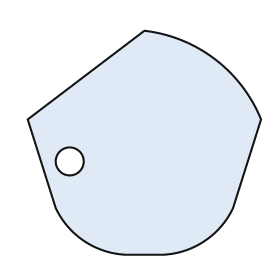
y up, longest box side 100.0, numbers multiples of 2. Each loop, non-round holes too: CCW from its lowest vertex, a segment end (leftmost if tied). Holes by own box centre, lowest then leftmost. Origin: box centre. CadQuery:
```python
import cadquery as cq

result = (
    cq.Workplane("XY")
    .moveTo(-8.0, -48.0)
    .lineTo(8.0, -48.0)
    .threePointArc((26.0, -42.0), (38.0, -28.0))
    .lineTo(50.0, 10.0)
    .threePointArc((30.0, 36.0), (0.0, 48.0))
    .lineTo(-50.0, 10.0)
    .lineTo(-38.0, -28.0)
    .threePointArc((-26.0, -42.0), (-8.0, -48.0))
    .close()
    .moveTo(-32.0, -8.0)
    .circle(6.0)
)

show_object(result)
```